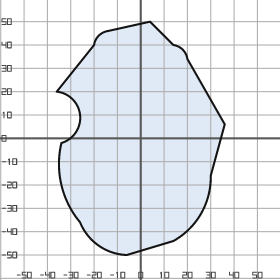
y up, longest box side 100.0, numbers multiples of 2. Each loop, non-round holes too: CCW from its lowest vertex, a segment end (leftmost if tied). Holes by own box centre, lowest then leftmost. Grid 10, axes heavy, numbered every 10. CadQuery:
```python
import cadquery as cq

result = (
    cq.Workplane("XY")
    .moveTo(-6.0, -50.0)
    .lineTo(14.0, -44.0)
    .threePointArc((26.0, -32.0), (30.0, -16.0))
    .lineTo(36.0, 6.0)
    .lineTo(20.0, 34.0)
    .threePointArc((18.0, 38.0), (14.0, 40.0))
    .lineTo(4.0, 50.0)
    .lineTo(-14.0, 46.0)
    .threePointArc((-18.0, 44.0), (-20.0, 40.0))
    .lineTo(-36.0, 20.0)
    .threePointArc((-26.0, 10.0), (-34.0, -2.0))
    .threePointArc((-34.0, -20.0), (-26.0, -36.0))
    .threePointArc((-18.0, -46.0), (-6.0, -50.0))
    .close()
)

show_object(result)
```